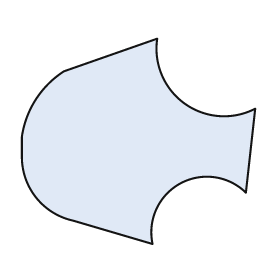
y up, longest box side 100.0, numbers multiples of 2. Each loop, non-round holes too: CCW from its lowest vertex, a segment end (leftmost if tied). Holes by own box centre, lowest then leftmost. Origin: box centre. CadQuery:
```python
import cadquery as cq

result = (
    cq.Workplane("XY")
    .moveTo(6.0, -44.0)
    .threePointArc((18.0, -18.0), (46.0, -22.0))
    .lineTo(50.0, 14.0)
    .threePointArc((20.0, 16.0), (8.0, 44.0))
    .lineTo(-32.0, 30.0)
    .threePointArc((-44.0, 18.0), (-50.0, 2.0))
    .lineTo(-50.0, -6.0)
    .threePointArc((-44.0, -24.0), (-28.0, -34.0))
    .close()
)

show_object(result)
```